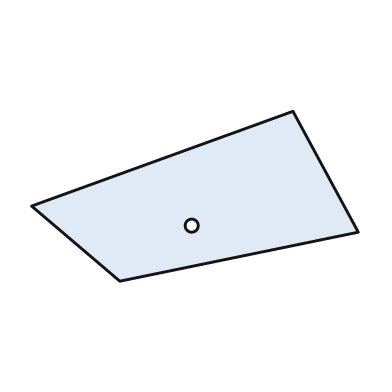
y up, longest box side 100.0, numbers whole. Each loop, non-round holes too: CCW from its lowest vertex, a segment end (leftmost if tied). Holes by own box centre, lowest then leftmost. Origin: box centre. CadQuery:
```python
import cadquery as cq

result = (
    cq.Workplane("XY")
    .moveTo(-23.0, -26.0)
    .lineTo(50.0, -11.0)
    .lineTo(30.0, 26.0)
    .lineTo(-50.0, -3.0)
    .close()
    .moveTo(-1.0, -9.0)
    .circle(2.0)
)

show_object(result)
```